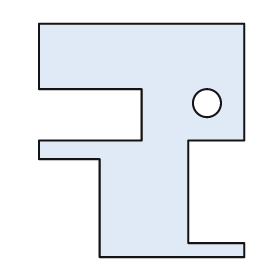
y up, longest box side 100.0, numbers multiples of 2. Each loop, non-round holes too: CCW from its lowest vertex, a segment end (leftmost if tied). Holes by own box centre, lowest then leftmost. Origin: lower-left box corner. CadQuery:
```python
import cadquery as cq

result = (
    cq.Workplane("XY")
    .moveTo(26.0, 0.0)
    .lineTo(88.0, 0.0)
    .lineTo(88.0, 6.0)
    .lineTo(64.0, 6.0)
    .lineTo(64.0, 50.0)
    .lineTo(88.0, 50.0)
    .lineTo(88.0, 100.0)
    .lineTo(0.0, 100.0)
    .lineTo(0.0, 72.0)
    .lineTo(44.0, 72.0)
    .lineTo(44.0, 50.0)
    .lineTo(0.0, 50.0)
    .lineTo(0.0, 42.0)
    .lineTo(26.0, 42.0)
    .close()
    .moveTo(72.0, 66.0)
    .circle(6.0)
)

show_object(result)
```